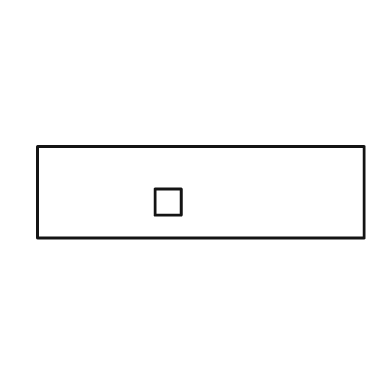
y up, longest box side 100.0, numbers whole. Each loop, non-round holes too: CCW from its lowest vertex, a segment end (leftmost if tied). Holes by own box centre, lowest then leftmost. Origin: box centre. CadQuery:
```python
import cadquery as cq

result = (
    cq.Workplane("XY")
    .moveTo(-50.0, -14.0)
    .lineTo(50.0, -14.0)
    .lineTo(50.0, 14.0)
    .lineTo(-50.0, 14.0)
    .close()
    .moveTo(-14.0, -7.0)
    .lineTo(-6.0, -7.0)
    .lineTo(-6.0, 1.0)
    .lineTo(-14.0, 1.0)
    .close()
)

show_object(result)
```